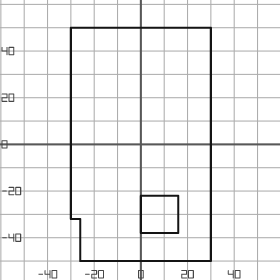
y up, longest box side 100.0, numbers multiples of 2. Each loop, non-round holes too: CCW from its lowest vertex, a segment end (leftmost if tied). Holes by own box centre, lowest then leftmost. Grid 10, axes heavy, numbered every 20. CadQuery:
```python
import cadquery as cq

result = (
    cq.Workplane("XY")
    .moveTo(-26.0, -50.0)
    .lineTo(30.0, -50.0)
    .lineTo(30.0, 50.0)
    .lineTo(-30.0, 50.0)
    .lineTo(-30.0, -32.0)
    .lineTo(-26.0, -32.0)
    .close()
    .moveTo(0.0, -38.0)
    .lineTo(16.0, -38.0)
    .lineTo(16.0, -22.0)
    .lineTo(0.0, -22.0)
    .close()
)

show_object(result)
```